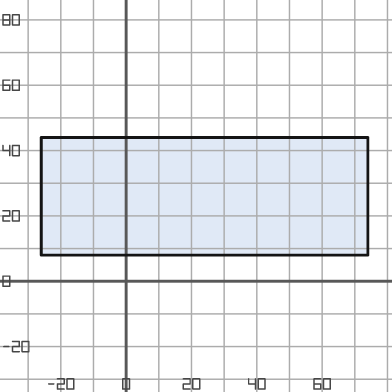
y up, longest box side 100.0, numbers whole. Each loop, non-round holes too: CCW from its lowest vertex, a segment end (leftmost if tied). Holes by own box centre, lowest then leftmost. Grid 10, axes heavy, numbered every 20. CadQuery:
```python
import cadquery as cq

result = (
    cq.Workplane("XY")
    .moveTo(-26.0, 8.0)
    .lineTo(74.0, 8.0)
    .lineTo(74.0, 44.0)
    .lineTo(-26.0, 44.0)
    .close()
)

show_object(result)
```